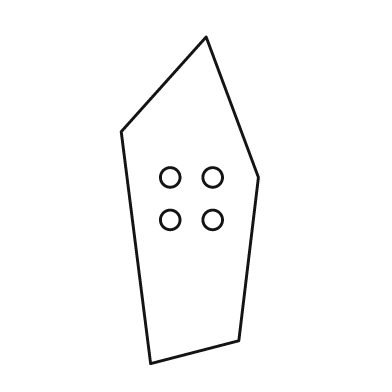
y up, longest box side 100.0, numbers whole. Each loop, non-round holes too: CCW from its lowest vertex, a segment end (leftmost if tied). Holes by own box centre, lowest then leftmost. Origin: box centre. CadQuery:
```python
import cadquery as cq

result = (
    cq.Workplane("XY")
    .moveTo(-12.0, -50.0)
    .lineTo(15.0, -43.0)
    .lineTo(21.0, 7.0)
    .lineTo(5.0, 50.0)
    .lineTo(-21.0, 21.0)
    .close()
    .moveTo(-6.0, -6.0)
    .circle(3.0)
    .moveTo(7.0, -6.0)
    .circle(3.0)
    .moveTo(-6.0, 7.0)
    .circle(3.0)
    .moveTo(7.0, 7.0)
    .circle(3.0)
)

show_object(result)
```